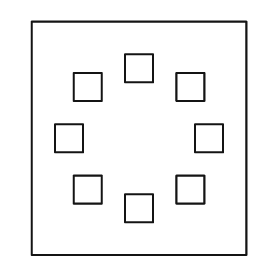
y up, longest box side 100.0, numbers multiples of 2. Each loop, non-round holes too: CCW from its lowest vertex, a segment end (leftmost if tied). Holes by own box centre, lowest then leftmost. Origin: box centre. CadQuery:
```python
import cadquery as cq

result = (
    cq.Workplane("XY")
    .moveTo(-46.0, -50.0)
    .lineTo(46.0, -50.0)
    .lineTo(46.0, 50.0)
    .lineTo(-46.0, 50.0)
    .close()
    .moveTo(-6.0, -36.0)
    .lineTo(6.0, -36.0)
    .lineTo(6.0, -24.0)
    .lineTo(-6.0, -24.0)
    .close()
    .moveTo(-28.0, -28.0)
    .lineTo(-16.0, -28.0)
    .lineTo(-16.0, -16.0)
    .lineTo(-28.0, -16.0)
    .close()
    .moveTo(16.0, -28.0)
    .lineTo(28.0, -28.0)
    .lineTo(28.0, -16.0)
    .lineTo(16.0, -16.0)
    .close()
    .moveTo(-36.0, -6.0)
    .lineTo(-24.0, -6.0)
    .lineTo(-24.0, 6.0)
    .lineTo(-36.0, 6.0)
    .close()
    .moveTo(24.0, -6.0)
    .lineTo(36.0, -6.0)
    .lineTo(36.0, 6.0)
    .lineTo(24.0, 6.0)
    .close()
    .moveTo(-28.0, 16.0)
    .lineTo(-16.0, 16.0)
    .lineTo(-16.0, 28.0)
    .lineTo(-28.0, 28.0)
    .close()
    .moveTo(16.0, 16.0)
    .lineTo(28.0, 16.0)
    .lineTo(28.0, 28.0)
    .lineTo(16.0, 28.0)
    .close()
    .moveTo(-6.0, 24.0)
    .lineTo(6.0, 24.0)
    .lineTo(6.0, 36.0)
    .lineTo(-6.0, 36.0)
    .close()
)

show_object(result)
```